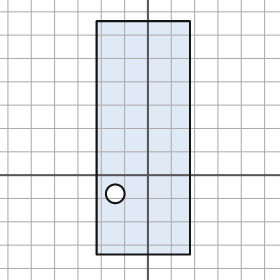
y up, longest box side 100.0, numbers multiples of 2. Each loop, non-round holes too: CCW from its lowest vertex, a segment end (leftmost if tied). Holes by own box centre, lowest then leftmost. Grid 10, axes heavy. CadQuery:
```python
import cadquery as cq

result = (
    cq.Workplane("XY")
    .moveTo(-22.0, -34.0)
    .lineTo(18.0, -34.0)
    .lineTo(18.0, 66.0)
    .lineTo(-22.0, 66.0)
    .close()
    .moveTo(-14.0, -8.0)
    .circle(4.0)
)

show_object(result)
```